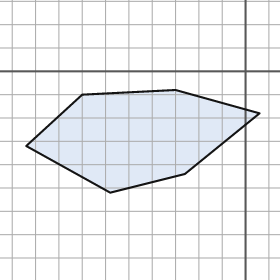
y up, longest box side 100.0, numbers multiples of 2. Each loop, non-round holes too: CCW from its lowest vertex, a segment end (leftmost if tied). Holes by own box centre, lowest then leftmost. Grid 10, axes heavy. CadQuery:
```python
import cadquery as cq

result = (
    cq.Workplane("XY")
    .moveTo(-58.0, -52.0)
    .lineTo(-26.0, -44.0)
    .lineTo(6.0, -18.0)
    .lineTo(-30.0, -8.0)
    .lineTo(-70.0, -10.0)
    .lineTo(-94.0, -32.0)
    .close()
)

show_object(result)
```